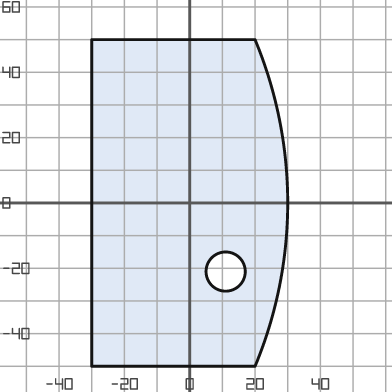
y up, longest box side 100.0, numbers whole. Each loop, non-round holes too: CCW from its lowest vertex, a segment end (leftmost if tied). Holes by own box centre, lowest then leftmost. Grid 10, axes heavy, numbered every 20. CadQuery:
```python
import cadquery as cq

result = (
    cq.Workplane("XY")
    .moveTo(-30.0, -50.0)
    .lineTo(20.0, -50.0)
    .threePointArc((30.0, 0.0), (20.0, 50.0))
    .lineTo(-30.0, 50.0)
    .close()
    .moveTo(11.0, -21.0)
    .circle(6.0)
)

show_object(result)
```